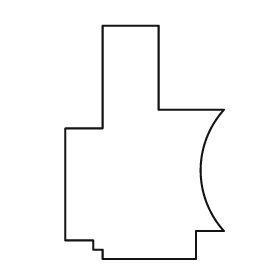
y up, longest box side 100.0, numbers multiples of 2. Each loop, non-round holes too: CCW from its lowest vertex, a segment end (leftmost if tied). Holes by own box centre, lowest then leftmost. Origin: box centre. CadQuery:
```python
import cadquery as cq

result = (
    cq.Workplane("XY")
    .moveTo(-18.0, -50.0)
    .lineTo(22.0, -50.0)
    .lineTo(22.0, -38.0)
    .lineTo(34.0, -38.0)
    .threePointArc((24.0, -12.0), (34.0, 14.0))
    .lineTo(6.0, 14.0)
    .lineTo(6.0, 50.0)
    .lineTo(-18.0, 50.0)
    .lineTo(-18.0, 6.0)
    .lineTo(-34.0, 6.0)
    .lineTo(-34.0, -42.0)
    .lineTo(-22.0, -42.0)
    .lineTo(-22.0, -46.0)
    .lineTo(-18.0, -46.0)
    .close()
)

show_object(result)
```